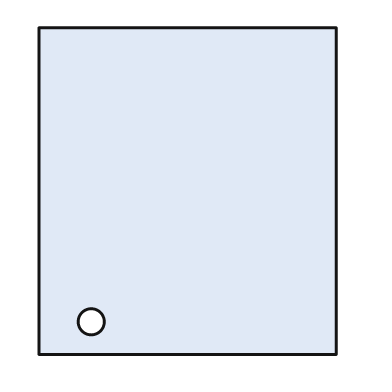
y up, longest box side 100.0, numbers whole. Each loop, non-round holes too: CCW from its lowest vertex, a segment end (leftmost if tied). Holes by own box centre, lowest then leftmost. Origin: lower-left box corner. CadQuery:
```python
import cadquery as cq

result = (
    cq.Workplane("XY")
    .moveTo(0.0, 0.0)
    .lineTo(91.0, 0.0)
    .lineTo(91.0, 100.0)
    .lineTo(0.0, 100.0)
    .close()
    .moveTo(16.0, 10.0)
    .circle(4.0)
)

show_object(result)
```